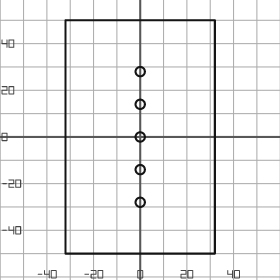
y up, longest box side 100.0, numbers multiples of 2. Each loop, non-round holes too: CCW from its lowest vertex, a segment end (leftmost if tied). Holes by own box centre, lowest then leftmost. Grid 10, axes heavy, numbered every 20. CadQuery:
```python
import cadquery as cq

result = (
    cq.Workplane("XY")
    .moveTo(-32.0, -50.0)
    .lineTo(32.0, -50.0)
    .lineTo(32.0, 50.0)
    .lineTo(-32.0, 50.0)
    .close()
    .moveTo(0.0, -28.0)
    .circle(2.0)
    .moveTo(0.0, -14.0)
    .circle(2.0)
    .moveTo(0.0, 0.0)
    .circle(2.0)
    .moveTo(0.0, 14.0)
    .circle(2.0)
    .moveTo(0.0, 28.0)
    .circle(2.0)
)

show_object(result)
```